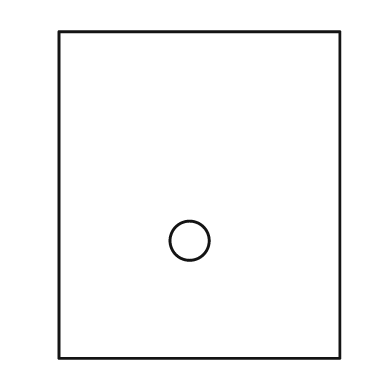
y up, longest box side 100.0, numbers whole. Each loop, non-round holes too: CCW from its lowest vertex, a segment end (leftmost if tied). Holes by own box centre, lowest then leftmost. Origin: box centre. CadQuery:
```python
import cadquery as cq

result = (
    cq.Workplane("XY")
    .moveTo(-43.0, -50.0)
    .lineTo(43.0, -50.0)
    .lineTo(43.0, 50.0)
    .lineTo(-43.0, 50.0)
    .close()
    .moveTo(-3.0, -14.0)
    .circle(6.0)
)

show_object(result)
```